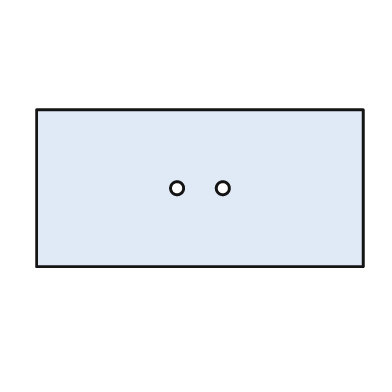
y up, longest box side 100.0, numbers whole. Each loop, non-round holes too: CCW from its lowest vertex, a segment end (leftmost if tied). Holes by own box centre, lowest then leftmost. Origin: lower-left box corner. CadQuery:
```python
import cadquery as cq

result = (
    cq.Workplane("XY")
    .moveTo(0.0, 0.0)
    .lineTo(100.0, 0.0)
    .lineTo(100.0, 48.0)
    .lineTo(0.0, 48.0)
    .close()
    .moveTo(43.0, 24.0)
    .circle(2.0)
    .moveTo(57.0, 24.0)
    .circle(2.0)
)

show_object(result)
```